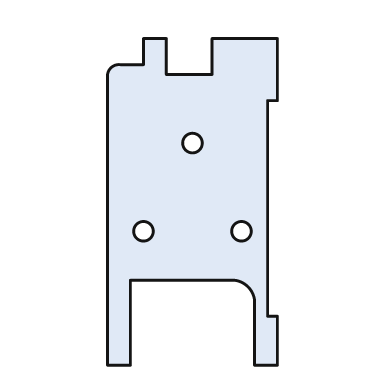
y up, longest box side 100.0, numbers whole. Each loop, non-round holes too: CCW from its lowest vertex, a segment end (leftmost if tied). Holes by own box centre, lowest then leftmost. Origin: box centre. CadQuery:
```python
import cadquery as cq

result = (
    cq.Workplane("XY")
    .moveTo(-26.0, -50.0)
    .lineTo(-19.0, -50.0)
    .lineTo(-19.0, -24.0)
    .lineTo(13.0, -24.0)
    .threePointArc((17.0, -26.0), (19.0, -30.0))
    .lineTo(19.0, -50.0)
    .lineTo(26.0, -50.0)
    .lineTo(26.0, -35.0)
    .lineTo(23.0, -35.0)
    .lineTo(23.0, 31.0)
    .lineTo(26.0, 31.0)
    .lineTo(26.0, 50.0)
    .lineTo(6.0, 50.0)
    .lineTo(6.0, 39.0)
    .lineTo(-8.0, 39.0)
    .lineTo(-8.0, 50.0)
    .lineTo(-15.0, 50.0)
    .lineTo(-15.0, 42.0)
    .lineTo(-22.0, 42.0)
    .threePointArc((-25.0, 41.0), (-26.0, 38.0))
    .close()
    .moveTo(-15.0, -9.0)
    .circle(3.0)
    .moveTo(15.0, -9.0)
    .circle(3.0)
    .moveTo(0.0, 18.0)
    .circle(3.0)
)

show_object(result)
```